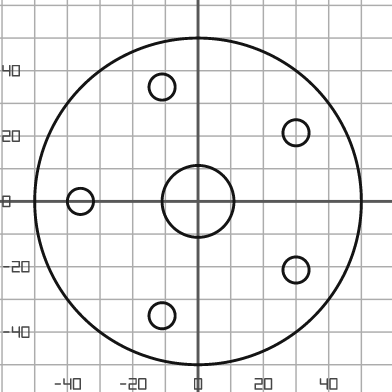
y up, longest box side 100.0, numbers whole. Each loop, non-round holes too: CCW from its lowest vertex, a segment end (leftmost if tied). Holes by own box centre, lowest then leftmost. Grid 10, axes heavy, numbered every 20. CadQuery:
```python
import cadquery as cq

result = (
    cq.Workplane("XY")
    .moveTo(0.0, 0.0)
    .circle(50.0)
    .moveTo(-11.0, -35.0)
    .circle(4.0)
    .moveTo(30.0, -21.0)
    .circle(4.0)
    .moveTo(-36.0, 0.0)
    .circle(4.0)
    .moveTo(0.0, 0.0)
    .circle(11.0)
    .moveTo(30.0, 21.0)
    .circle(4.0)
    .moveTo(-11.0, 35.0)
    .circle(4.0)
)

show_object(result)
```